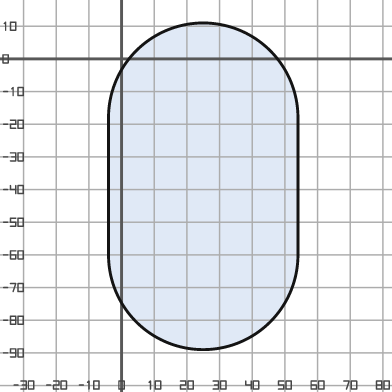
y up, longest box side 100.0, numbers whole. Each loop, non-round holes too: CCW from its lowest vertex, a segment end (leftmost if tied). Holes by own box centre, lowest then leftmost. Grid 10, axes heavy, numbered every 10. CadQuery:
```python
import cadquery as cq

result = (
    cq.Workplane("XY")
    .moveTo(-4.0, -60.0)
    .threePointArc((25.0, -89.0), (54.0, -60.0))
    .lineTo(54.0, -18.0)
    .threePointArc((25.0, 11.0), (-4.0, -18.0))
    .close()
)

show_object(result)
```